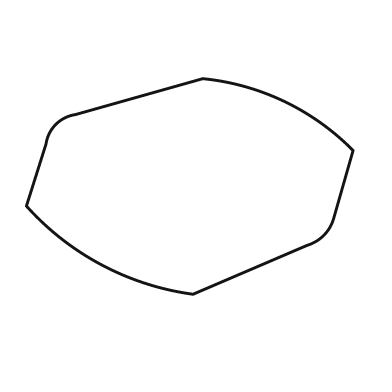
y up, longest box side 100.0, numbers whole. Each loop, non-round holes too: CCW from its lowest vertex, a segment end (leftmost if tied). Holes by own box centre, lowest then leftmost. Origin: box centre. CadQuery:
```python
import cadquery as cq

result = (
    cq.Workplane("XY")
    .moveTo(1.0, -33.0)
    .lineTo(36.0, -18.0)
    .threePointArc((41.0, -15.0), (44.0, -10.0))
    .lineTo(50.0, 11.0)
    .threePointArc((29.0, 26.0), (4.0, 33.0))
    .lineTo(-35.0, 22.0)
    .threePointArc((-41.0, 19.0), (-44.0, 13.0))
    .lineTo(-50.0, -6.0)
    .threePointArc((-27.0, -24.0), (1.0, -33.0))
    .close()
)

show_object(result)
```